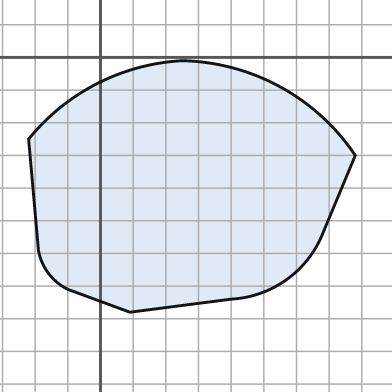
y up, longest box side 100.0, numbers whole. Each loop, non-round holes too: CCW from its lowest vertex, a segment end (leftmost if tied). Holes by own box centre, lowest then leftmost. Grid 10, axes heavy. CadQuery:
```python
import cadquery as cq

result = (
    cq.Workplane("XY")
    .moveTo(9.0, -78.0)
    .lineTo(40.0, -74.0)
    .threePointArc((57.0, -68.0), (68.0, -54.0))
    .lineTo(78.0, -30.0)
    .threePointArc((55.0, -9.0), (25.0, -1.0))
    .threePointArc((-1.0, -8.0), (-22.0, -25.0))
    .lineTo(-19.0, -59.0)
    .threePointArc((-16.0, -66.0), (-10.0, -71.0))
    .close()
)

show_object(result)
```